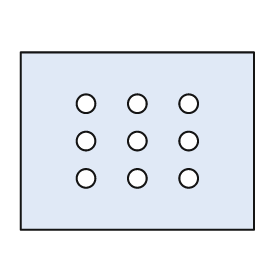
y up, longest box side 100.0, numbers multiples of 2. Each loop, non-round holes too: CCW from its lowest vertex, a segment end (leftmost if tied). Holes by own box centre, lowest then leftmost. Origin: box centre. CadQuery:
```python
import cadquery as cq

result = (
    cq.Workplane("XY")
    .moveTo(-50.0, -38.0)
    .lineTo(50.0, -38.0)
    .lineTo(50.0, 38.0)
    .lineTo(-50.0, 38.0)
    .close()
    .moveTo(-22.0, -16.0)
    .circle(4.0)
    .moveTo(0.0, -16.0)
    .circle(4.0)
    .moveTo(22.0, -16.0)
    .circle(4.0)
    .moveTo(-22.0, 0.0)
    .circle(4.0)
    .moveTo(0.0, 0.0)
    .circle(4.0)
    .moveTo(22.0, 0.0)
    .circle(4.0)
    .moveTo(-22.0, 16.0)
    .circle(4.0)
    .moveTo(0.0, 16.0)
    .circle(4.0)
    .moveTo(22.0, 16.0)
    .circle(4.0)
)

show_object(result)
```